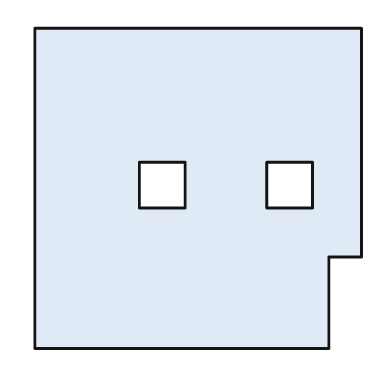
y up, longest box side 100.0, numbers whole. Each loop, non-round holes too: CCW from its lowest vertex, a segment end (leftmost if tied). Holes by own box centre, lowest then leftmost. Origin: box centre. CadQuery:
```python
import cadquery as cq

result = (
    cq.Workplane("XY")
    .moveTo(-50.0, -49.0)
    .lineTo(40.0, -49.0)
    .lineTo(40.0, -21.0)
    .lineTo(50.0, -21.0)
    .lineTo(50.0, 49.0)
    .lineTo(-50.0, 49.0)
    .close()
    .moveTo(-18.0, -6.0)
    .lineTo(-4.0, -6.0)
    .lineTo(-4.0, 8.0)
    .lineTo(-18.0, 8.0)
    .close()
    .moveTo(21.0, -6.0)
    .lineTo(35.0, -6.0)
    .lineTo(35.0, 8.0)
    .lineTo(21.0, 8.0)
    .close()
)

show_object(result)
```